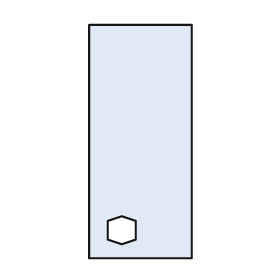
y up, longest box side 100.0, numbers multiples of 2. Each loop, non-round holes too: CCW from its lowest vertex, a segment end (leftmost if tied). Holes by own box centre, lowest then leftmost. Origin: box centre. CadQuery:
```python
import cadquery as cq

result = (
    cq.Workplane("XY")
    .moveTo(-22.0, -50.0)
    .lineTo(22.0, -50.0)
    .lineTo(22.0, 50.0)
    .lineTo(-22.0, 50.0)
    .close()
    .moveTo(-8.0, -44.0)
    .lineTo(-2.0, -42.0)
    .lineTo(-2.0, -34.0)
    .lineTo(-8.0, -32.0)
    .lineTo(-14.0, -34.0)
    .lineTo(-14.0, -42.0)
    .close()
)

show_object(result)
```